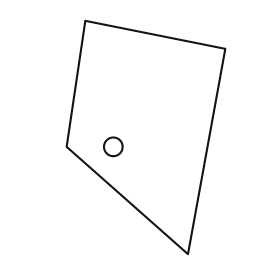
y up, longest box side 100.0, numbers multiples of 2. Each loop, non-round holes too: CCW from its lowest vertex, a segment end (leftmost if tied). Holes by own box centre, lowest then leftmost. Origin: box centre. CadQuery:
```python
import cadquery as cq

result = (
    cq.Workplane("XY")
    .moveTo(18.0, -50.0)
    .lineTo(34.0, 38.0)
    .lineTo(-26.0, 50.0)
    .lineTo(-34.0, -4.0)
    .close()
    .moveTo(-14.0, -4.0)
    .circle(4.0)
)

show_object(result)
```